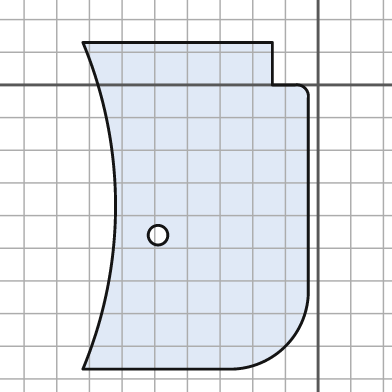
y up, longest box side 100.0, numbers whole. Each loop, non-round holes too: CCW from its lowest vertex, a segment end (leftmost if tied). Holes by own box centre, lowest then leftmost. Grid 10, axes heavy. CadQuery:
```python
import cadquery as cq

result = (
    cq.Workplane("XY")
    .moveTo(-72.0, -87.0)
    .lineTo(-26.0, -87.0)
    .threePointArc((-10.0, -80.0), (-3.0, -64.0))
    .lineTo(-3.0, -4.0)
    .threePointArc((-4.0, -1.0), (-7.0, 0.0))
    .lineTo(-14.0, 0.0)
    .lineTo(-14.0, 13.0)
    .lineTo(-72.0, 13.0)
    .threePointArc((-62.0, -37.0), (-72.0, -87.0))
    .close()
    .moveTo(-49.0, -46.0)
    .circle(3.0)
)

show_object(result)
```